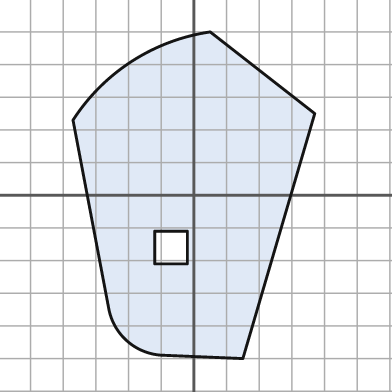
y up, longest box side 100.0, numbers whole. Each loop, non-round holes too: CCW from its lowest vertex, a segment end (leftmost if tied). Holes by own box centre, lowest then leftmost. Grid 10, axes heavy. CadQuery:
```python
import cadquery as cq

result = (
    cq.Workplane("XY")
    .moveTo(15.0, -50.0)
    .lineTo(37.0, 25.0)
    .lineTo(5.0, 50.0)
    .threePointArc((-19.0, 41.0), (-37.0, 23.0))
    .lineTo(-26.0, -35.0)
    .threePointArc((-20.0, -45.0), (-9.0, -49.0))
    .close()
    .moveTo(-12.0, -21.0)
    .lineTo(-2.0, -21.0)
    .lineTo(-2.0, -11.0)
    .lineTo(-12.0, -11.0)
    .close()
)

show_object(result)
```